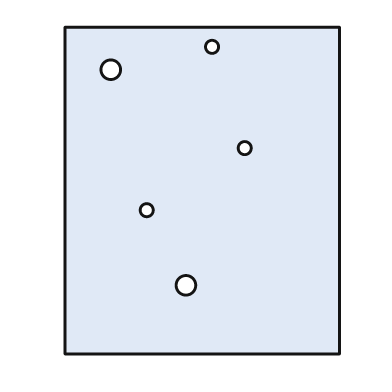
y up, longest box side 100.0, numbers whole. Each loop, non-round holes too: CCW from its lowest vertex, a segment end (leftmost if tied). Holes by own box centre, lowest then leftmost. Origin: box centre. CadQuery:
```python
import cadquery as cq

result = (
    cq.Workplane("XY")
    .moveTo(-42.0, -50.0)
    .lineTo(42.0, -50.0)
    .lineTo(42.0, 50.0)
    .lineTo(-42.0, 50.0)
    .close()
    .moveTo(-5.0, -29.0)
    .circle(3.0)
    .moveTo(-17.0, -6.0)
    .circle(2.0)
    .moveTo(13.0, 13.0)
    .circle(2.0)
    .moveTo(-28.0, 37.0)
    .circle(3.0)
    .moveTo(3.0, 44.0)
    .circle(2.0)
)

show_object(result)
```